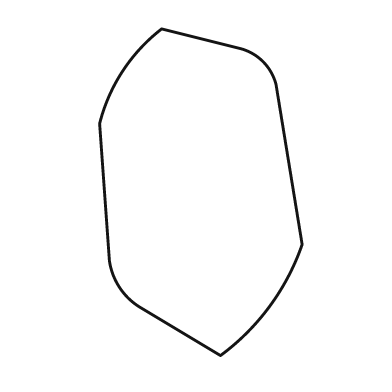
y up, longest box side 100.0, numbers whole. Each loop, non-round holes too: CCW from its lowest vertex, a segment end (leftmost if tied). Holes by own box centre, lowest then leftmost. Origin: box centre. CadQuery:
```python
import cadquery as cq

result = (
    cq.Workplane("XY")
    .moveTo(6.0, -50.0)
    .threePointArc((21.0, -35.0), (31.0, -16.0))
    .lineTo(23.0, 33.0)
    .threePointArc((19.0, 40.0), (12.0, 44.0))
    .lineTo(-12.0, 50.0)
    .threePointArc((-24.0, 37.0), (-31.0, 21.0))
    .lineTo(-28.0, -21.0)
    .threePointArc((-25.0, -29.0), (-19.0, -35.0))
    .close()
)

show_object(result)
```